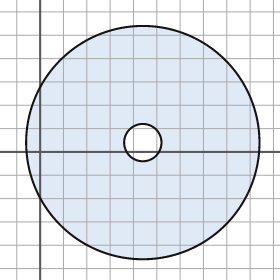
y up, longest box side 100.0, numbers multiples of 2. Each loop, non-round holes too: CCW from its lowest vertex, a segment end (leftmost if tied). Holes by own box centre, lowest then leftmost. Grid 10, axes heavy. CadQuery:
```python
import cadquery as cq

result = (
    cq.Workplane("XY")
    .moveTo(44.0, 4.0)
    .circle(50.0)
    .moveTo(44.0, 4.0)
    .circle(8.0)
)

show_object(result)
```